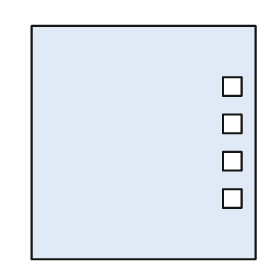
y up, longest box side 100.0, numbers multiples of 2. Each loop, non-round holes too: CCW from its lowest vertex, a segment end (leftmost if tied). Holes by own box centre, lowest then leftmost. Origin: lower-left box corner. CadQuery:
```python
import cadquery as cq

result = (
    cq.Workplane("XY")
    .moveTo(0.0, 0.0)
    .lineTo(96.0, 0.0)
    .lineTo(96.0, 100.0)
    .lineTo(0.0, 100.0)
    .close()
    .moveTo(82.0, 22.0)
    .lineTo(90.0, 22.0)
    .lineTo(90.0, 30.0)
    .lineTo(82.0, 30.0)
    .close()
    .moveTo(82.0, 38.0)
    .lineTo(90.0, 38.0)
    .lineTo(90.0, 46.0)
    .lineTo(82.0, 46.0)
    .close()
    .moveTo(82.0, 54.0)
    .lineTo(90.0, 54.0)
    .lineTo(90.0, 62.0)
    .lineTo(82.0, 62.0)
    .close()
    .moveTo(82.0, 70.0)
    .lineTo(90.0, 70.0)
    .lineTo(90.0, 78.0)
    .lineTo(82.0, 78.0)
    .close()
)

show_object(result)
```